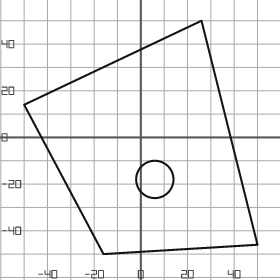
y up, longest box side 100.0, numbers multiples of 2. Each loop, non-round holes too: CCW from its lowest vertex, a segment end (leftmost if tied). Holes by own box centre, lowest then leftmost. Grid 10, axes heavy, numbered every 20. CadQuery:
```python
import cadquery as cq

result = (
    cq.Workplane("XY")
    .moveTo(-16.0, -50.0)
    .lineTo(50.0, -46.0)
    .lineTo(26.0, 50.0)
    .lineTo(-50.0, 14.0)
    .close()
    .moveTo(6.0, -18.0)
    .circle(8.0)
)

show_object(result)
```